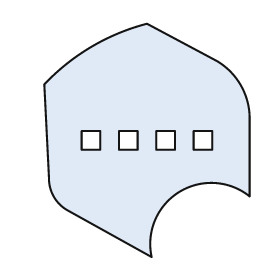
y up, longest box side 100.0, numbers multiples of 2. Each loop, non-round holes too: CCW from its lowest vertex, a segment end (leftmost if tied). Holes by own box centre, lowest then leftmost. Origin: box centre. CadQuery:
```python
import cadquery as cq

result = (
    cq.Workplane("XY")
    .moveTo(2.0, -50.0)
    .threePointArc((14.0, -22.0), (44.0, -24.0))
    .lineTo(44.0, 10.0)
    .threePointArc((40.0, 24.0), (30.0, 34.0))
    .lineTo(0.0, 50.0)
    .threePointArc((-24.0, 40.0), (-44.0, 24.0))
    .lineTo(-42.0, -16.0)
    .threePointArc((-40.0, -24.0), (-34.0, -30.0))
    .close()
    .moveTo(-28.0, -4.0)
    .lineTo(-20.0, -4.0)
    .lineTo(-20.0, 4.0)
    .lineTo(-28.0, 4.0)
    .close()
    .moveTo(-12.0, -4.0)
    .lineTo(-4.0, -4.0)
    .lineTo(-4.0, 4.0)
    .lineTo(-12.0, 4.0)
    .close()
    .moveTo(4.0, -4.0)
    .lineTo(12.0, -4.0)
    .lineTo(12.0, 4.0)
    .lineTo(4.0, 4.0)
    .close()
    .moveTo(20.0, -4.0)
    .lineTo(28.0, -4.0)
    .lineTo(28.0, 4.0)
    .lineTo(20.0, 4.0)
    .close()
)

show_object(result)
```